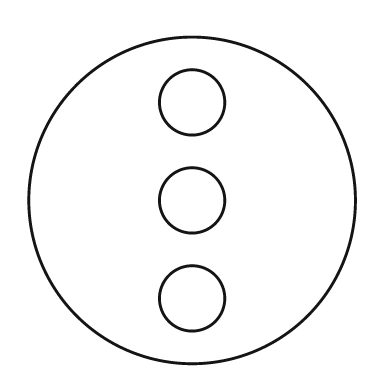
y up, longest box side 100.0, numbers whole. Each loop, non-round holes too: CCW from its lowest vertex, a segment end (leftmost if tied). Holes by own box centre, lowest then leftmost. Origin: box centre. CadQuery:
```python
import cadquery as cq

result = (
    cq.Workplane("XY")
    .moveTo(0.0, 0.0)
    .circle(50.0)
    .moveTo(0.0, -30.0)
    .circle(10.0)
    .moveTo(0.0, 0.0)
    .circle(10.0)
    .moveTo(0.0, 30.0)
    .circle(10.0)
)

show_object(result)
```